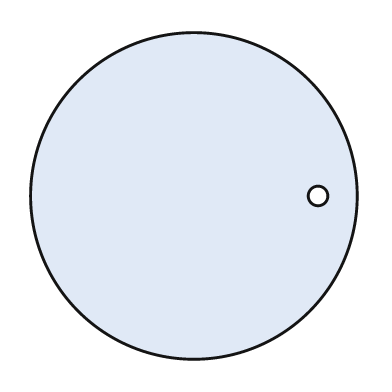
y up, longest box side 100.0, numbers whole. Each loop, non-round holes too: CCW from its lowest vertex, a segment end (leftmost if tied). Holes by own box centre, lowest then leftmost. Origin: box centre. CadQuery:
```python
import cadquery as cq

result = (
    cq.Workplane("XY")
    .moveTo(0.0, 0.0)
    .circle(50.0)
    .moveTo(38.0, 0.0)
    .circle(3.0)
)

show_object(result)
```